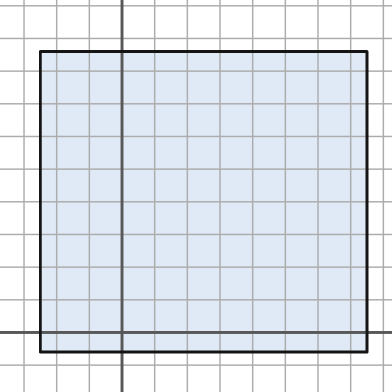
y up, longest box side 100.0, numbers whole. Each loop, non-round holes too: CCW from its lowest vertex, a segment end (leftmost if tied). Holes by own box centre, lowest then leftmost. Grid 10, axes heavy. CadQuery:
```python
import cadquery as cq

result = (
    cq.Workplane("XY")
    .moveTo(-25.0, -6.0)
    .lineTo(75.0, -6.0)
    .lineTo(75.0, 86.0)
    .lineTo(-25.0, 86.0)
    .close()
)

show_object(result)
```